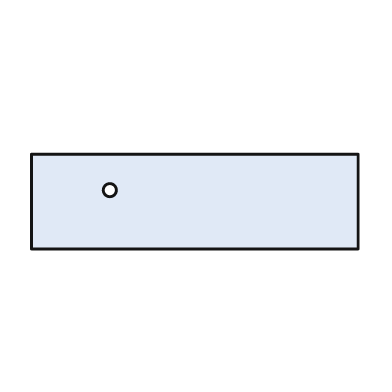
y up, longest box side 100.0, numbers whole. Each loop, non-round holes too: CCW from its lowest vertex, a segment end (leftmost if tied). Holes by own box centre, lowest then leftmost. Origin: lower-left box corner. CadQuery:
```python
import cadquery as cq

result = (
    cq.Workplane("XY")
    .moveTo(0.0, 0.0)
    .lineTo(100.0, 0.0)
    .lineTo(100.0, 29.0)
    .lineTo(0.0, 29.0)
    .close()
    .moveTo(24.0, 18.0)
    .circle(2.0)
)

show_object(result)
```